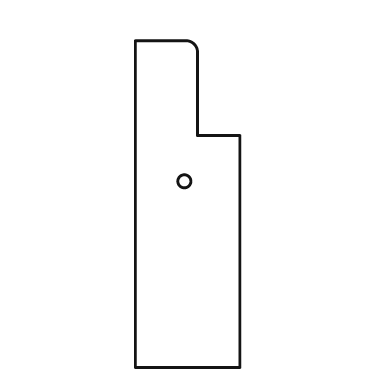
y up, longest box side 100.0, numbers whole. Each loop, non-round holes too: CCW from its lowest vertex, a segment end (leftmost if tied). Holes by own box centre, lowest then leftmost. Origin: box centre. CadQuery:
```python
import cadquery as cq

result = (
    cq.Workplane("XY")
    .moveTo(-16.0, -50.0)
    .lineTo(16.0, -50.0)
    .lineTo(16.0, 21.0)
    .lineTo(3.0, 21.0)
    .lineTo(3.0, 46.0)
    .threePointArc((2.0, 49.0), (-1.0, 50.0))
    .lineTo(-16.0, 50.0)
    .close()
    .moveTo(-1.0, 7.0)
    .circle(2.0)
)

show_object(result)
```